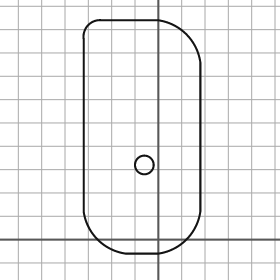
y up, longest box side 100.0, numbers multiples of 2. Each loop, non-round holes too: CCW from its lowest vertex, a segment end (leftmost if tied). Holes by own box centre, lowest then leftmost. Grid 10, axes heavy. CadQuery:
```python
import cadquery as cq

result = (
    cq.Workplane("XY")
    .moveTo(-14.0, -6.0)
    .lineTo(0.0, -6.0)
    .threePointArc((12.0, 0.0), (18.0, 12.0))
    .lineTo(18.0, 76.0)
    .threePointArc((12.0, 88.0), (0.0, 94.0))
    .lineTo(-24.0, 94.0)
    .threePointArc((-30.0, 92.0), (-32.0, 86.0))
    .lineTo(-32.0, 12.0)
    .threePointArc((-26.0, 0.0), (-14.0, -6.0))
    .close()
    .moveTo(-6.0, 32.0)
    .circle(4.0)
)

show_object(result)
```